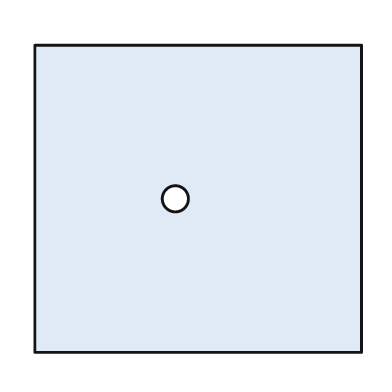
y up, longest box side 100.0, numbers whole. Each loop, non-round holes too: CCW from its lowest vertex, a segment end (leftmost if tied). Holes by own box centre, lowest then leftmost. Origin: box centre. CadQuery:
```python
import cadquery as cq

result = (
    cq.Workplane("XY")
    .moveTo(-50.0, -47.0)
    .lineTo(50.0, -47.0)
    .lineTo(50.0, 47.0)
    .lineTo(-50.0, 47.0)
    .close()
    .moveTo(-7.0, 0.0)
    .circle(4.0)
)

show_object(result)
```